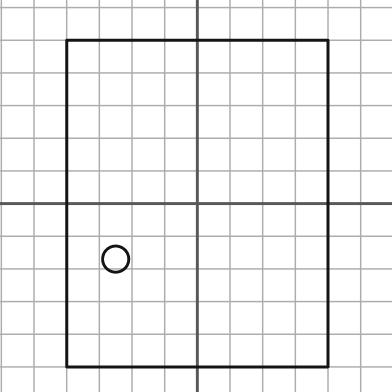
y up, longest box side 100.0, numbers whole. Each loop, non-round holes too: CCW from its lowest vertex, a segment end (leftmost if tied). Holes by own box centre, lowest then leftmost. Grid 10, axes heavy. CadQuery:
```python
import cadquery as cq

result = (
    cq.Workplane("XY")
    .moveTo(-40.0, -50.0)
    .lineTo(40.0, -50.0)
    .lineTo(40.0, 50.0)
    .lineTo(-40.0, 50.0)
    .close()
    .moveTo(-25.0, -17.0)
    .circle(4.0)
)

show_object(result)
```